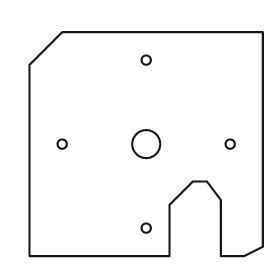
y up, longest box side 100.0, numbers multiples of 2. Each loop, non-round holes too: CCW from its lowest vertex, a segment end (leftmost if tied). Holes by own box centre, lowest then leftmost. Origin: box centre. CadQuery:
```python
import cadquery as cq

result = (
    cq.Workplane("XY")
    .moveTo(-50.0, -48.0)
    .lineTo(10.0, -48.0)
    .lineTo(10.0, -26.0)
    .lineTo(20.0, -16.0)
    .lineTo(26.0, -16.0)
    .lineTo(32.0, -24.0)
    .lineTo(32.0, -48.0)
    .lineTo(42.0, -48.0)
    .lineTo(50.0, -44.0)
    .lineTo(50.0, 48.0)
    .lineTo(-36.0, 48.0)
    .lineTo(-50.0, 34.0)
    .close()
    .moveTo(0.0, -36.0)
    .circle(2.0)
    .moveTo(-36.0, 0.0)
    .circle(2.0)
    .moveTo(0.0, 0.0)
    .circle(6.0)
    .moveTo(36.0, 0.0)
    .circle(2.0)
    .moveTo(0.0, 36.0)
    .circle(2.0)
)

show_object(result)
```